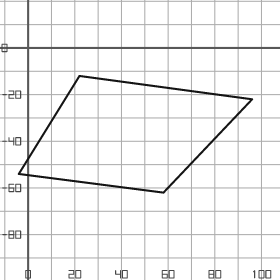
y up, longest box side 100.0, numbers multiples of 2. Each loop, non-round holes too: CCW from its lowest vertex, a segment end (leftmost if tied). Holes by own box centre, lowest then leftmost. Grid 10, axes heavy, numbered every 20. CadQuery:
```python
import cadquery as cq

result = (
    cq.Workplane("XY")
    .moveTo(58.0, -62.0)
    .lineTo(96.0, -22.0)
    .lineTo(22.0, -12.0)
    .lineTo(-4.0, -54.0)
    .close()
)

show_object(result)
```